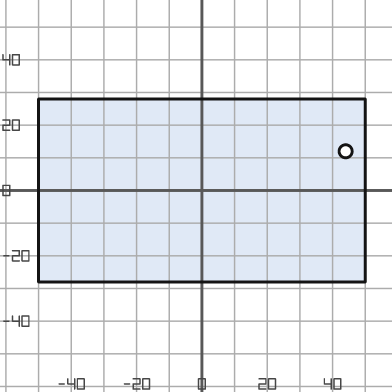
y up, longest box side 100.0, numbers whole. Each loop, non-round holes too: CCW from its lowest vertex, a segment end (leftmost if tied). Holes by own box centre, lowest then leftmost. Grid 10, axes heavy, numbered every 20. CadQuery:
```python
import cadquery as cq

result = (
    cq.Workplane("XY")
    .moveTo(-50.0, -28.0)
    .lineTo(50.0, -28.0)
    .lineTo(50.0, 28.0)
    .lineTo(-50.0, 28.0)
    .close()
    .moveTo(44.0, 12.0)
    .circle(2.0)
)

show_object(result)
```